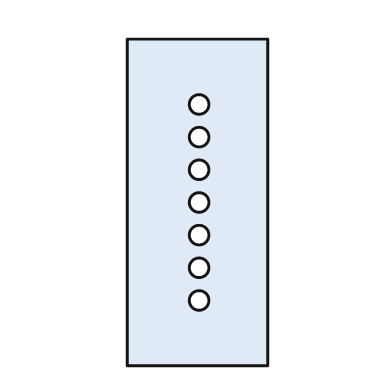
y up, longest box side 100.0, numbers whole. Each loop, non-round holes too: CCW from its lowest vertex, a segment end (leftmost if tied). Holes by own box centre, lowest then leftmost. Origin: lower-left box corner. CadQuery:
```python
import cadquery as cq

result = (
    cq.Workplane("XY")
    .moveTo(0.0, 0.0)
    .lineTo(43.0, 0.0)
    .lineTo(43.0, 100.0)
    .lineTo(0.0, 100.0)
    .close()
    .moveTo(22.0, 20.0)
    .circle(3.0)
    .moveTo(22.0, 30.0)
    .circle(3.0)
    .moveTo(22.0, 40.0)
    .circle(3.0)
    .moveTo(22.0, 50.0)
    .circle(3.0)
    .moveTo(22.0, 60.0)
    .circle(3.0)
    .moveTo(22.0, 70.0)
    .circle(3.0)
    .moveTo(22.0, 80.0)
    .circle(3.0)
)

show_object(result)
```